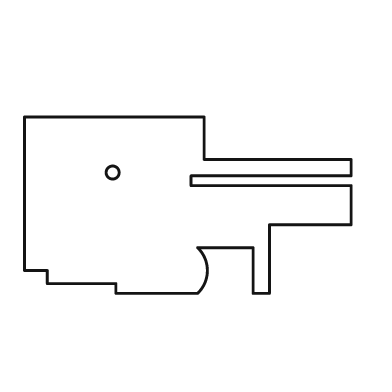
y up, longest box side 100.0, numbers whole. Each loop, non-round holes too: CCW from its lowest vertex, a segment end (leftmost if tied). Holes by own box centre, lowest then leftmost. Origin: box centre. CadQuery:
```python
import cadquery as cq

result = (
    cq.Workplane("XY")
    .moveTo(-22.0, -27.0)
    .lineTo(3.0, -27.0)
    .threePointArc((6.0, -20.0), (3.0, -13.0))
    .lineTo(20.0, -13.0)
    .lineTo(20.0, -27.0)
    .lineTo(25.0, -27.0)
    .lineTo(25.0, -6.0)
    .lineTo(50.0, -6.0)
    .lineTo(50.0, 6.0)
    .lineTo(1.0, 6.0)
    .lineTo(1.0, 9.0)
    .lineTo(50.0, 9.0)
    .lineTo(50.0, 14.0)
    .lineTo(5.0, 14.0)
    .lineTo(5.0, 27.0)
    .lineTo(-50.0, 27.0)
    .lineTo(-50.0, -20.0)
    .lineTo(-43.0, -20.0)
    .lineTo(-43.0, -24.0)
    .lineTo(-22.0, -24.0)
    .close()
    .moveTo(-23.0, 10.0)
    .circle(2.0)
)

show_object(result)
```